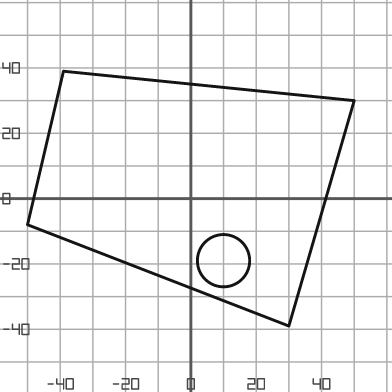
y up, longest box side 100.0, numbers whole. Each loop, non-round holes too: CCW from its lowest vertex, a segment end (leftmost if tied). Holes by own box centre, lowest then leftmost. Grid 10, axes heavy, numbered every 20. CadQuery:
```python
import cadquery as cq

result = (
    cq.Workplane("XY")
    .moveTo(30.0, -39.0)
    .lineTo(50.0, 30.0)
    .lineTo(-39.0, 39.0)
    .lineTo(-50.0, -8.0)
    .close()
    .moveTo(10.0, -19.0)
    .circle(8.0)
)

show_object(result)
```